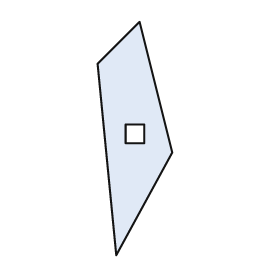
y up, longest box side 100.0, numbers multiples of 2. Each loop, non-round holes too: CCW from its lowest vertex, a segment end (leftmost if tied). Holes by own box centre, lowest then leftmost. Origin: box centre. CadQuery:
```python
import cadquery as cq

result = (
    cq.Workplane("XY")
    .moveTo(-8.0, -50.0)
    .lineTo(16.0, -6.0)
    .lineTo(2.0, 50.0)
    .lineTo(-16.0, 32.0)
    .close()
    .moveTo(-4.0, -2.0)
    .lineTo(4.0, -2.0)
    .lineTo(4.0, 6.0)
    .lineTo(-4.0, 6.0)
    .close()
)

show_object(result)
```